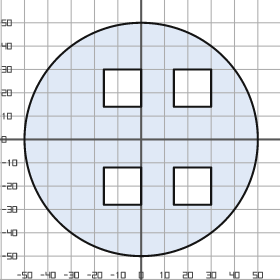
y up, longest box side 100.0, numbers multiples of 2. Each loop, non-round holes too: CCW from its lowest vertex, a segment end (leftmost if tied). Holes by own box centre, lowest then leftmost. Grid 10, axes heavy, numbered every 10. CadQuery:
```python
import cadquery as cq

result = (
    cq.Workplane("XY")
    .moveTo(0.0, 0.0)
    .circle(50.0)
    .moveTo(-16.0, -28.0)
    .lineTo(0.0, -28.0)
    .lineTo(0.0, -12.0)
    .lineTo(-16.0, -12.0)
    .close()
    .moveTo(14.0, -28.0)
    .lineTo(30.0, -28.0)
    .lineTo(30.0, -12.0)
    .lineTo(14.0, -12.0)
    .close()
    .moveTo(-16.0, 14.0)
    .lineTo(0.0, 14.0)
    .lineTo(0.0, 30.0)
    .lineTo(-16.0, 30.0)
    .close()
    .moveTo(14.0, 14.0)
    .lineTo(30.0, 14.0)
    .lineTo(30.0, 30.0)
    .lineTo(14.0, 30.0)
    .close()
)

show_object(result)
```